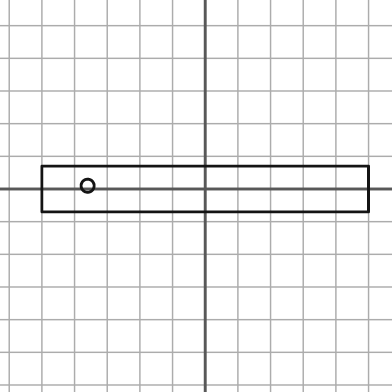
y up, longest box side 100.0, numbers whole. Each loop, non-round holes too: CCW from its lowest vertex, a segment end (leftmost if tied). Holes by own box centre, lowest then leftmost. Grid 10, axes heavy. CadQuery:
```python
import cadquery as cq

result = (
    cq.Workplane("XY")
    .moveTo(-50.0, -7.0)
    .lineTo(50.0, -7.0)
    .lineTo(50.0, 7.0)
    .lineTo(-50.0, 7.0)
    .close()
    .moveTo(-36.0, 1.0)
    .circle(2.0)
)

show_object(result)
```